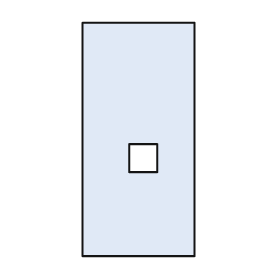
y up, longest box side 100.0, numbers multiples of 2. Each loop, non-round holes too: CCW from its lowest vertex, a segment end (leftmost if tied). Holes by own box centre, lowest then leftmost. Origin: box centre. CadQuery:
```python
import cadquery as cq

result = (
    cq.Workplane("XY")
    .moveTo(-24.0, -50.0)
    .lineTo(24.0, -50.0)
    .lineTo(24.0, 50.0)
    .lineTo(-24.0, 50.0)
    .close()
    .moveTo(-4.0, -14.0)
    .lineTo(8.0, -14.0)
    .lineTo(8.0, -2.0)
    .lineTo(-4.0, -2.0)
    .close()
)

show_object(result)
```